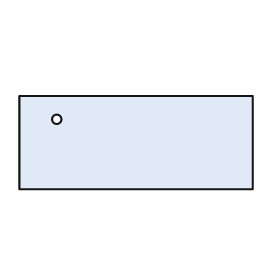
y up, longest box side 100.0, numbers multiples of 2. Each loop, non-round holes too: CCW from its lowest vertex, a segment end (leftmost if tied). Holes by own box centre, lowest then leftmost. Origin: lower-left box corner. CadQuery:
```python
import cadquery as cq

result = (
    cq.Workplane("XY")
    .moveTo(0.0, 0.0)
    .lineTo(100.0, 0.0)
    .lineTo(100.0, 40.0)
    .lineTo(0.0, 40.0)
    .close()
    .moveTo(16.0, 30.0)
    .circle(2.0)
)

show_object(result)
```